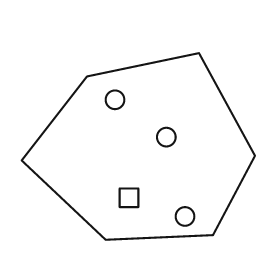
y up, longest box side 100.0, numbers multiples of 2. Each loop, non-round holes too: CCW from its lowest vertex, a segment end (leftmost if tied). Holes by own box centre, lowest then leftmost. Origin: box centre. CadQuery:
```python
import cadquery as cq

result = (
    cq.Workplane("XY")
    .moveTo(-14.0, -40.0)
    .lineTo(32.0, -38.0)
    .lineTo(50.0, -4.0)
    .lineTo(26.0, 40.0)
    .lineTo(-22.0, 30.0)
    .lineTo(-50.0, -6.0)
    .close()
    .moveTo(20.0, -30.0)
    .circle(4.0)
    .moveTo(-8.0, -26.0)
    .lineTo(0.0, -26.0)
    .lineTo(0.0, -18.0)
    .lineTo(-8.0, -18.0)
    .close()
    .moveTo(12.0, 4.0)
    .circle(4.0)
    .moveTo(-10.0, 20.0)
    .circle(4.0)
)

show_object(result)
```